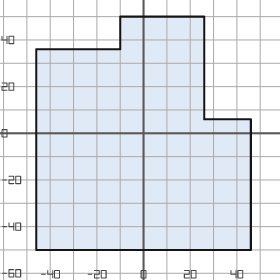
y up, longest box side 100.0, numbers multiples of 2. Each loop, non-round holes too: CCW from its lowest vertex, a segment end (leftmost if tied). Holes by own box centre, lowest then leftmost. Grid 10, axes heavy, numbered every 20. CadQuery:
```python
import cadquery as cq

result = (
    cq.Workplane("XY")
    .moveTo(-46.0, -50.0)
    .lineTo(46.0, -50.0)
    .lineTo(46.0, 6.0)
    .lineTo(26.0, 6.0)
    .lineTo(26.0, 50.0)
    .lineTo(-10.0, 50.0)
    .lineTo(-10.0, 36.0)
    .lineTo(-46.0, 36.0)
    .close()
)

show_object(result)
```